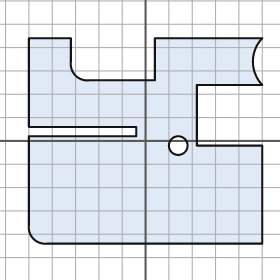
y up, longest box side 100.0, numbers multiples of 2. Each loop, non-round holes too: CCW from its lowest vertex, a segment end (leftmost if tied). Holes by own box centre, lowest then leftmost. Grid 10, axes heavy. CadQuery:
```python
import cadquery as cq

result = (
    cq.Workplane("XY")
    .moveTo(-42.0, -44.0)
    .lineTo(50.0, -44.0)
    .lineTo(50.0, -2.0)
    .lineTo(22.0, -2.0)
    .lineTo(22.0, 24.0)
    .lineTo(50.0, 24.0)
    .threePointArc((46.0, 34.0), (50.0, 44.0))
    .lineTo(4.0, 44.0)
    .lineTo(4.0, 26.0)
    .lineTo(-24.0, 26.0)
    .threePointArc((-30.0, 28.0), (-32.0, 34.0))
    .lineTo(-32.0, 44.0)
    .lineTo(-50.0, 44.0)
    .lineTo(-50.0, 6.0)
    .lineTo(-4.0, 6.0)
    .lineTo(-4.0, 2.0)
    .lineTo(-50.0, 2.0)
    .lineTo(-50.0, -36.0)
    .threePointArc((-48.0, -42.0), (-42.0, -44.0))
    .close()
    .moveTo(14.0, -2.0)
    .circle(4.0)
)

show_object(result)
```